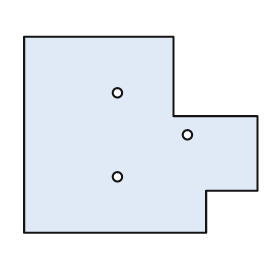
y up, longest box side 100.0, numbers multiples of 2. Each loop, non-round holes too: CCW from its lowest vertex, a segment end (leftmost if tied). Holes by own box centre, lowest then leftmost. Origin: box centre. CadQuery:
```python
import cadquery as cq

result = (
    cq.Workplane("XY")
    .moveTo(-50.0, -42.0)
    .lineTo(28.0, -42.0)
    .lineTo(28.0, -24.0)
    .lineTo(50.0, -24.0)
    .lineTo(50.0, 8.0)
    .lineTo(14.0, 8.0)
    .lineTo(14.0, 42.0)
    .lineTo(-50.0, 42.0)
    .close()
    .moveTo(-10.0, -18.0)
    .circle(2.0)
    .moveTo(20.0, 0.0)
    .circle(2.0)
    .moveTo(-10.0, 18.0)
    .circle(2.0)
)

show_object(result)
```